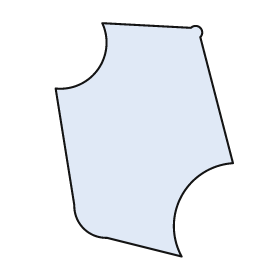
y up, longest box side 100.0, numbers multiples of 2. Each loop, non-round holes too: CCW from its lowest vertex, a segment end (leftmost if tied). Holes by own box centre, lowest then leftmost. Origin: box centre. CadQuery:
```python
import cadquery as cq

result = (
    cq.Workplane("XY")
    .moveTo(16.0, -50.0)
    .threePointArc((16.0, -24.0), (38.0, -10.0))
    .lineTo(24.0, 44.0)
    .threePointArc((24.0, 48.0), (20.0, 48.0))
    .lineTo(-18.0, 50.0)
    .threePointArc((-20.0, 30.0), (-38.0, 22.0))
    .lineTo(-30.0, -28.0)
    .threePointArc((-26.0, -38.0), (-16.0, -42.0))
    .close()
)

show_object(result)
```